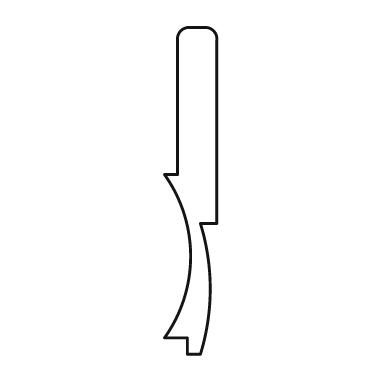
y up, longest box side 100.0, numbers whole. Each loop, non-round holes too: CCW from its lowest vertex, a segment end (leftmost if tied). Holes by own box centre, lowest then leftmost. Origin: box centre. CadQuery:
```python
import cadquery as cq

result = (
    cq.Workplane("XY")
    .moveTo(-1.0, -50.0)
    .lineTo(3.0, -50.0)
    .threePointArc((6.0, -30.0), (3.0, -10.0))
    .lineTo(8.0, -10.0)
    .lineTo(8.0, 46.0)
    .threePointArc((7.0, 49.0), (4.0, 50.0))
    .lineTo(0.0, 50.0)
    .threePointArc((-3.0, 49.0), (-4.0, 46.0))
    .lineTo(-4.0, 5.0)
    .lineTo(-8.0, 5.0)
    .threePointArc((0.0, -20.0), (-8.0, -45.0))
    .lineTo(-1.0, -45.0)
    .close()
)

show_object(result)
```